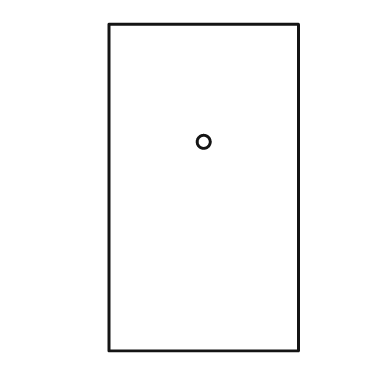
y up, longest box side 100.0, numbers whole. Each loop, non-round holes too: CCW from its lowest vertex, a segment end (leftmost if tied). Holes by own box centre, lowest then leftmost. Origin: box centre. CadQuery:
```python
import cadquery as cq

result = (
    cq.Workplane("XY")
    .moveTo(-29.0, -50.0)
    .lineTo(29.0, -50.0)
    .lineTo(29.0, 50.0)
    .lineTo(-29.0, 50.0)
    .close()
    .moveTo(0.0, 14.0)
    .circle(2.0)
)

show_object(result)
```